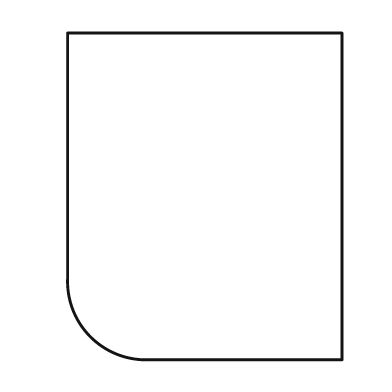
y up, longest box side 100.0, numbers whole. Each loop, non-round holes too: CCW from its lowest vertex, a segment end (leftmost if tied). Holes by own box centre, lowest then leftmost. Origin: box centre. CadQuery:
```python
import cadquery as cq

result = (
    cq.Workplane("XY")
    .moveTo(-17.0, -50.0)
    .lineTo(42.0, -50.0)
    .lineTo(42.0, 50.0)
    .lineTo(-42.0, 50.0)
    .lineTo(-42.0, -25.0)
    .threePointArc((-35.0, -43.0), (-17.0, -50.0))
    .close()
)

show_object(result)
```